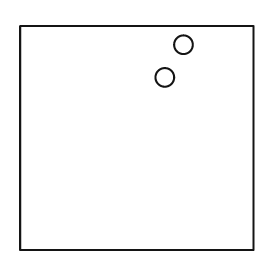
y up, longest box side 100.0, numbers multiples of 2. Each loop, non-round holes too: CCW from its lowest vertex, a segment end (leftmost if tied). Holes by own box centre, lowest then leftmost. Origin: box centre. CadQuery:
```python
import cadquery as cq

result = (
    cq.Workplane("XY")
    .moveTo(-50.0, -48.0)
    .lineTo(50.0, -48.0)
    .lineTo(50.0, 48.0)
    .lineTo(-50.0, 48.0)
    .close()
    .moveTo(12.0, 26.0)
    .circle(4.0)
    .moveTo(20.0, 40.0)
    .circle(4.0)
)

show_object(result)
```